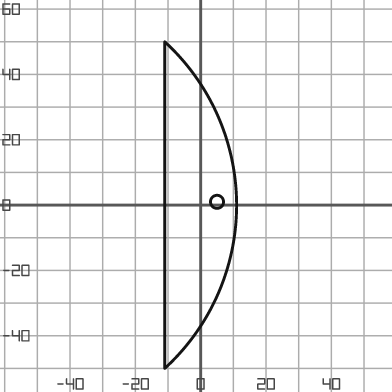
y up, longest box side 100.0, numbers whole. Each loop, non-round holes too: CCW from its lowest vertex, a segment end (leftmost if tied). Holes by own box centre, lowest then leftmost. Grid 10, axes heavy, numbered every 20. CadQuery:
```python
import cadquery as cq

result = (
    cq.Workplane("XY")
    .moveTo(-11.0, -50.0)
    .threePointArc((11.0, 0.0), (-11.0, 50.0))
    .close()
    .moveTo(5.0, 1.0)
    .circle(2.0)
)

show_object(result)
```